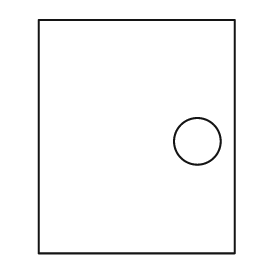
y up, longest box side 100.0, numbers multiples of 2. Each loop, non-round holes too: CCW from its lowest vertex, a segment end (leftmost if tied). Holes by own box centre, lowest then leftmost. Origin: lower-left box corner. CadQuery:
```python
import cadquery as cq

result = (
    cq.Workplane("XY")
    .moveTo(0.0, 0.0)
    .lineTo(84.0, 0.0)
    .lineTo(84.0, 100.0)
    .lineTo(0.0, 100.0)
    .close()
    .moveTo(68.0, 48.0)
    .circle(10.0)
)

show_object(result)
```